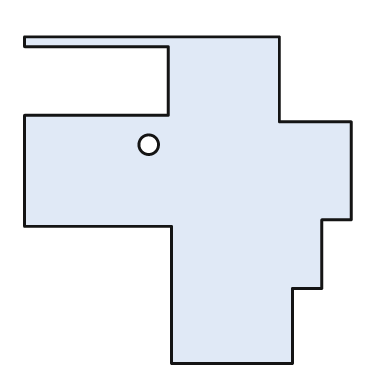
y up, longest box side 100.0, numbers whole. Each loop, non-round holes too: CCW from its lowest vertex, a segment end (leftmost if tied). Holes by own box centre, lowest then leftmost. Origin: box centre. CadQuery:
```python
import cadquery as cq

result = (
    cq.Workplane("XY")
    .moveTo(-5.0, -50.0)
    .lineTo(32.0, -50.0)
    .lineTo(32.0, -27.0)
    .lineTo(41.0, -27.0)
    .lineTo(41.0, -6.0)
    .lineTo(50.0, -6.0)
    .lineTo(50.0, 24.0)
    .lineTo(28.0, 24.0)
    .lineTo(28.0, 50.0)
    .lineTo(-50.0, 50.0)
    .lineTo(-50.0, 47.0)
    .lineTo(-6.0, 47.0)
    .lineTo(-6.0, 26.0)
    .lineTo(-50.0, 26.0)
    .lineTo(-50.0, -8.0)
    .lineTo(-5.0, -8.0)
    .close()
    .moveTo(-12.0, 17.0)
    .circle(3.0)
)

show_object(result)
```